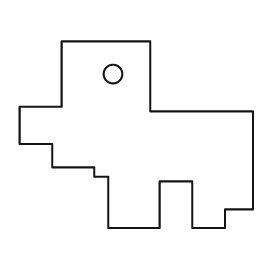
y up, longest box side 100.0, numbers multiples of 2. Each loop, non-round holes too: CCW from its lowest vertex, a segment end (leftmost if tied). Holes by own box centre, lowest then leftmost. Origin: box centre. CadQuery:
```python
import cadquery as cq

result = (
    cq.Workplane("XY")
    .moveTo(-12.0, -40.0)
    .lineTo(10.0, -40.0)
    .lineTo(10.0, -20.0)
    .lineTo(24.0, -20.0)
    .lineTo(24.0, -40.0)
    .lineTo(38.0, -40.0)
    .lineTo(38.0, -32.0)
    .lineTo(50.0, -32.0)
    .lineTo(50.0, 10.0)
    .lineTo(6.0, 10.0)
    .lineTo(6.0, 40.0)
    .lineTo(-32.0, 40.0)
    .lineTo(-32.0, 12.0)
    .lineTo(-50.0, 12.0)
    .lineTo(-50.0, -4.0)
    .lineTo(-36.0, -4.0)
    .lineTo(-36.0, -14.0)
    .lineTo(-18.0, -14.0)
    .lineTo(-18.0, -18.0)
    .lineTo(-12.0, -18.0)
    .close()
    .moveTo(-10.0, 26.0)
    .circle(4.0)
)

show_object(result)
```